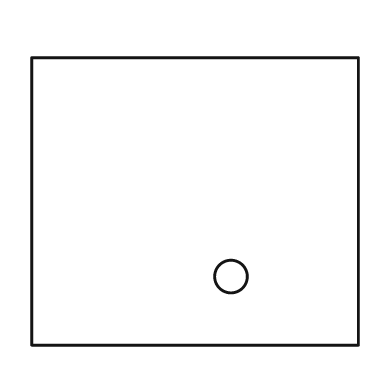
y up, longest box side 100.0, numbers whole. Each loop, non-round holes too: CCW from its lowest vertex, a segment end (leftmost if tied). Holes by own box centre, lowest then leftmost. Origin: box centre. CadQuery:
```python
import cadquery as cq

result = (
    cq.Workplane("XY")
    .moveTo(-50.0, -44.0)
    .lineTo(50.0, -44.0)
    .lineTo(50.0, 44.0)
    .lineTo(-50.0, 44.0)
    .close()
    .moveTo(11.0, -23.0)
    .circle(5.0)
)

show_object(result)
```